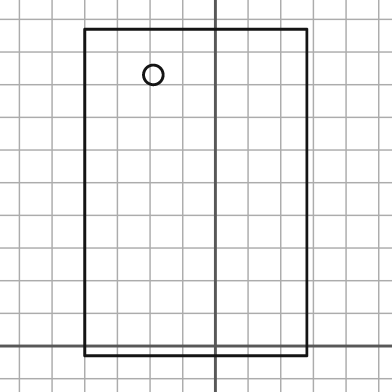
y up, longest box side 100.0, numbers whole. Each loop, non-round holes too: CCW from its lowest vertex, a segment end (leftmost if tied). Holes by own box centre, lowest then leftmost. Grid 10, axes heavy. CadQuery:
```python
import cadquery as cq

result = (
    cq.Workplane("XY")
    .moveTo(-40.0, -3.0)
    .lineTo(28.0, -3.0)
    .lineTo(28.0, 97.0)
    .lineTo(-40.0, 97.0)
    .close()
    .moveTo(-19.0, 83.0)
    .circle(3.0)
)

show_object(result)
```